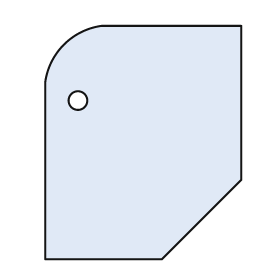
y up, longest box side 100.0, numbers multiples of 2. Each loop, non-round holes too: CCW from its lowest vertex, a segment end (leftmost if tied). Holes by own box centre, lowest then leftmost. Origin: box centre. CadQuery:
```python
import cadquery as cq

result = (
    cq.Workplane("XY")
    .moveTo(-42.0, -50.0)
    .lineTo(8.0, -50.0)
    .lineTo(42.0, -16.0)
    .lineTo(42.0, 50.0)
    .lineTo(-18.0, 50.0)
    .threePointArc((-34.0, 42.0), (-42.0, 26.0))
    .close()
    .moveTo(-28.0, 18.0)
    .circle(4.0)
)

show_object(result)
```